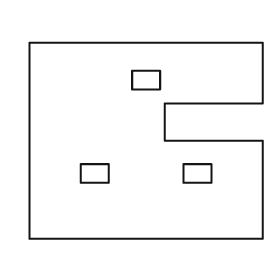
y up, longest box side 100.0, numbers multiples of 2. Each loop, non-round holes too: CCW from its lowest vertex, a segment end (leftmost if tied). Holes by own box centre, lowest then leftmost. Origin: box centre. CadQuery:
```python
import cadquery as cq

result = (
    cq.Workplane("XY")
    .moveTo(-50.0, -42.0)
    .lineTo(50.0, -42.0)
    .lineTo(50.0, 0.0)
    .lineTo(8.0, 0.0)
    .lineTo(8.0, 16.0)
    .lineTo(50.0, 16.0)
    .lineTo(50.0, 42.0)
    .lineTo(-50.0, 42.0)
    .close()
    .moveTo(-28.0, -18.0)
    .lineTo(-16.0, -18.0)
    .lineTo(-16.0, -10.0)
    .lineTo(-28.0, -10.0)
    .close()
    .moveTo(16.0, -18.0)
    .lineTo(28.0, -18.0)
    .lineTo(28.0, -10.0)
    .lineTo(16.0, -10.0)
    .close()
    .moveTo(-6.0, 22.0)
    .lineTo(6.0, 22.0)
    .lineTo(6.0, 30.0)
    .lineTo(-6.0, 30.0)
    .close()
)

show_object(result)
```